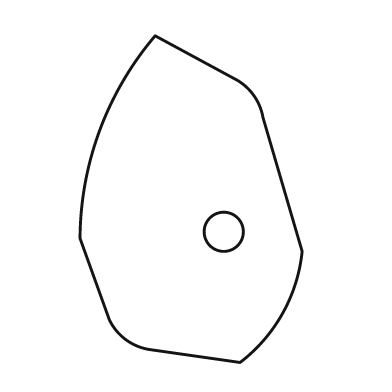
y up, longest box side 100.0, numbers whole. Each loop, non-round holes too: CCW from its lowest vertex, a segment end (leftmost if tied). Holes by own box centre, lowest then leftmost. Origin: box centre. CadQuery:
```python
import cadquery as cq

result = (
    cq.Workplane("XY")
    .moveTo(15.0, -50.0)
    .threePointArc((28.0, -35.0), (34.0, -16.0))
    .lineTo(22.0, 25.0)
    .threePointArc((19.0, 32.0), (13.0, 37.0))
    .lineTo(-11.0, 50.0)
    .threePointArc((-28.0, 21.0), (-34.0, -12.0))
    .lineTo(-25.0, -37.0)
    .threePointArc((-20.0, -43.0), (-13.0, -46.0))
    .close()
    .moveTo(10.0, -10.0)
    .circle(6.0)
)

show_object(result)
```